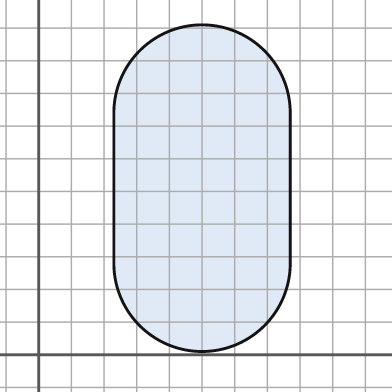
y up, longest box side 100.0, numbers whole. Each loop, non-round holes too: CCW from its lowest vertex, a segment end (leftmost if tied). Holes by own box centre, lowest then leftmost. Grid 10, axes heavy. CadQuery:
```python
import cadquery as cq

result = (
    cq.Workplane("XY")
    .moveTo(23.0, 28.0)
    .threePointArc((50.0, 1.0), (77.0, 28.0))
    .lineTo(77.0, 74.0)
    .threePointArc((50.0, 101.0), (23.0, 74.0))
    .close()
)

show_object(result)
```